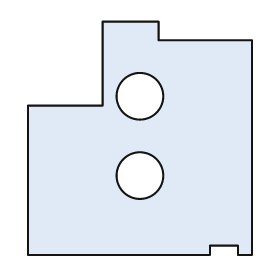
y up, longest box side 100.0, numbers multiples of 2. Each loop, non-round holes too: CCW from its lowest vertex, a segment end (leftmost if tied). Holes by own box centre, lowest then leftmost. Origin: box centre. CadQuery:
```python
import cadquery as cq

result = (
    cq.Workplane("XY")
    .moveTo(-48.0, -50.0)
    .lineTo(30.0, -50.0)
    .lineTo(30.0, -46.0)
    .lineTo(42.0, -46.0)
    .lineTo(42.0, -50.0)
    .lineTo(48.0, -50.0)
    .lineTo(48.0, 42.0)
    .lineTo(8.0, 42.0)
    .lineTo(8.0, 50.0)
    .lineTo(-16.0, 50.0)
    .lineTo(-16.0, 14.0)
    .lineTo(-48.0, 14.0)
    .close()
    .moveTo(0.0, -16.0)
    .circle(10.0)
    .moveTo(0.0, 18.0)
    .circle(10.0)
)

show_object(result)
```